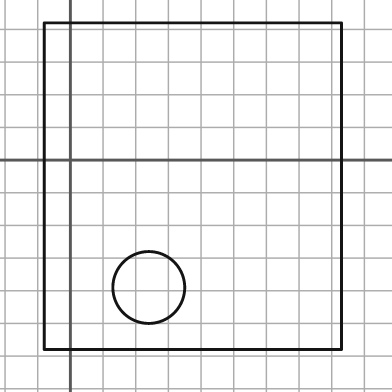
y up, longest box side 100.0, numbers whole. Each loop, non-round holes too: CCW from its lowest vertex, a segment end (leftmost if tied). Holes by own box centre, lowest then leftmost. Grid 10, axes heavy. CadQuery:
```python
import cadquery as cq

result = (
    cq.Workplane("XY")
    .moveTo(-8.0, -58.0)
    .lineTo(83.0, -58.0)
    .lineTo(83.0, 42.0)
    .lineTo(-8.0, 42.0)
    .close()
    .moveTo(24.0, -39.0)
    .circle(11.0)
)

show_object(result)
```